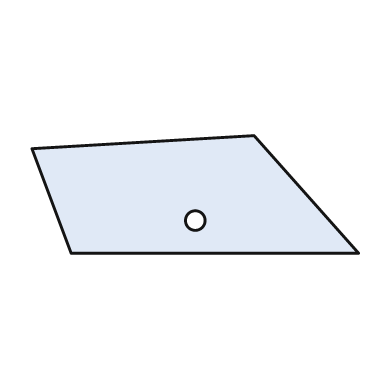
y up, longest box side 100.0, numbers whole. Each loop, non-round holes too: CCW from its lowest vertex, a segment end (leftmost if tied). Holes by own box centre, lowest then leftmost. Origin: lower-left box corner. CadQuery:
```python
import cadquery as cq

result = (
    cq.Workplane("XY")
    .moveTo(12.0, 0.0)
    .lineTo(100.0, 0.0)
    .lineTo(68.0, 36.0)
    .lineTo(0.0, 32.0)
    .close()
    .moveTo(50.0, 10.0)
    .circle(3.0)
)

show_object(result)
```